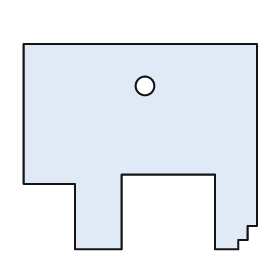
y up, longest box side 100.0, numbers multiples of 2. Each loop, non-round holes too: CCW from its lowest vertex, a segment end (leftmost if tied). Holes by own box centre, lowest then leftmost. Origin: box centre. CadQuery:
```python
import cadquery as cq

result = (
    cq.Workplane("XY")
    .moveTo(-28.0, -44.0)
    .lineTo(-8.0, -44.0)
    .lineTo(-8.0, -12.0)
    .lineTo(32.0, -12.0)
    .lineTo(32.0, -44.0)
    .lineTo(42.0, -44.0)
    .lineTo(42.0, -40.0)
    .lineTo(46.0, -40.0)
    .lineTo(46.0, -34.0)
    .lineTo(50.0, -34.0)
    .lineTo(50.0, 44.0)
    .lineTo(-50.0, 44.0)
    .lineTo(-50.0, -16.0)
    .lineTo(-28.0, -16.0)
    .close()
    .moveTo(2.0, 26.0)
    .circle(4.0)
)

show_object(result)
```